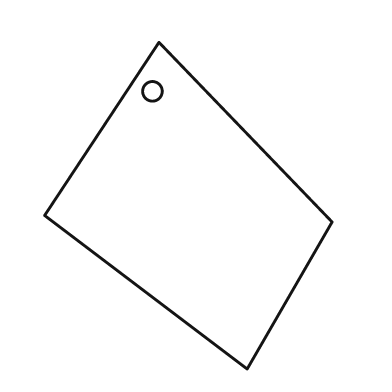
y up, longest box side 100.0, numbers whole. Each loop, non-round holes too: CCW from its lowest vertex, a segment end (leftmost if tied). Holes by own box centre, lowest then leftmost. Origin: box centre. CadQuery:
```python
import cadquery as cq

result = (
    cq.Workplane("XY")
    .moveTo(18.0, -50.0)
    .lineTo(44.0, -5.0)
    .lineTo(-9.0, 50.0)
    .lineTo(-44.0, -3.0)
    .close()
    .moveTo(-11.0, 35.0)
    .circle(3.0)
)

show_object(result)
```